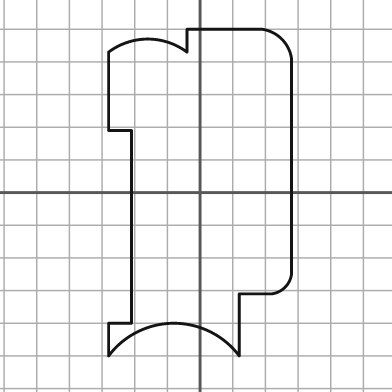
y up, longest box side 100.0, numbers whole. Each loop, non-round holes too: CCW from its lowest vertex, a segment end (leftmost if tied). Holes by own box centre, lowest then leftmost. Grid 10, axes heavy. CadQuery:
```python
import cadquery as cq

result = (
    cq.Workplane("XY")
    .moveTo(-28.0, -50.0)
    .threePointArc((-8.0, -40.0), (12.0, -50.0))
    .lineTo(12.0, -31.0)
    .lineTo(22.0, -31.0)
    .threePointArc((26.0, -29.0), (28.0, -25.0))
    .lineTo(28.0, 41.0)
    .threePointArc((25.0, 47.0), (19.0, 50.0))
    .lineTo(-4.0, 50.0)
    .lineTo(-4.0, 43.0)
    .threePointArc((-16.0, 47.0), (-28.0, 43.0))
    .lineTo(-28.0, 19.0)
    .lineTo(-21.0, 19.0)
    .lineTo(-21.0, -40.0)
    .lineTo(-28.0, -40.0)
    .close()
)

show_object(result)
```